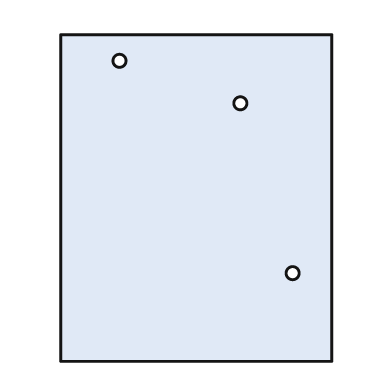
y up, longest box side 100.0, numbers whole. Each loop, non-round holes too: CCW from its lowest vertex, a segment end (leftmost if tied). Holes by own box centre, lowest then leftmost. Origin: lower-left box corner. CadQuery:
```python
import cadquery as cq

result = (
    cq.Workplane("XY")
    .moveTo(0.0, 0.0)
    .lineTo(83.0, 0.0)
    .lineTo(83.0, 100.0)
    .lineTo(0.0, 100.0)
    .close()
    .moveTo(71.0, 27.0)
    .circle(2.0)
    .moveTo(55.0, 79.0)
    .circle(2.0)
    .moveTo(18.0, 92.0)
    .circle(2.0)
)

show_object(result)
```